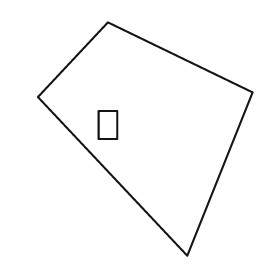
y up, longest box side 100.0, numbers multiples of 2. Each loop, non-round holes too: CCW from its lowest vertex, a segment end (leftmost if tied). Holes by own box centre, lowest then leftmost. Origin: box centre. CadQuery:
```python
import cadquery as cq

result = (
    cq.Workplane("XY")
    .moveTo(18.0, -50.0)
    .lineTo(46.0, 20.0)
    .lineTo(-16.0, 50.0)
    .lineTo(-46.0, 18.0)
    .close()
    .moveTo(-20.0, 0.0)
    .lineTo(-12.0, 0.0)
    .lineTo(-12.0, 12.0)
    .lineTo(-20.0, 12.0)
    .close()
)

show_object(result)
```